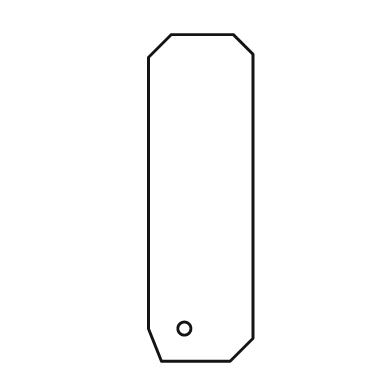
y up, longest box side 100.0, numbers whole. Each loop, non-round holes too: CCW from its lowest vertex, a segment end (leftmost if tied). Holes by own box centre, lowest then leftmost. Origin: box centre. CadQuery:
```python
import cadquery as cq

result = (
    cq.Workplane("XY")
    .moveTo(-12.0, -50.0)
    .lineTo(9.0, -50.0)
    .lineTo(16.0, -43.0)
    .lineTo(16.0, 44.0)
    .lineTo(10.0, 50.0)
    .lineTo(-9.0, 50.0)
    .lineTo(-16.0, 43.0)
    .lineTo(-16.0, -40.0)
    .close()
    .moveTo(-5.0, -40.0)
    .circle(2.0)
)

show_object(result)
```